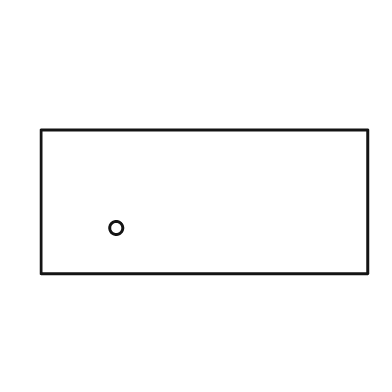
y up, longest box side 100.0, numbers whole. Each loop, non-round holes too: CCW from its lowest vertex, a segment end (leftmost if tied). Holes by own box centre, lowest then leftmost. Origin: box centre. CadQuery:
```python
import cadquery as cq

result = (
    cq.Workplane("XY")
    .moveTo(-50.0, -22.0)
    .lineTo(50.0, -22.0)
    .lineTo(50.0, 22.0)
    .lineTo(-50.0, 22.0)
    .close()
    .moveTo(-27.0, -8.0)
    .circle(2.0)
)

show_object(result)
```